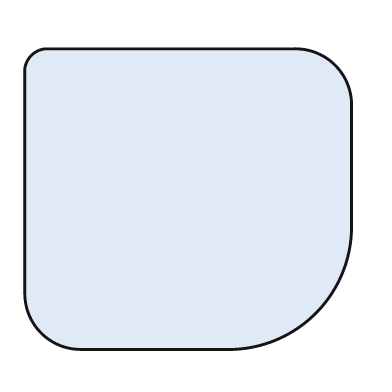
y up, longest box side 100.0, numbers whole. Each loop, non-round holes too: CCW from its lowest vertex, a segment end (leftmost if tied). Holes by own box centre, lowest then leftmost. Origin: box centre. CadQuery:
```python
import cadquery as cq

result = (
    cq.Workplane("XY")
    .moveTo(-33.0, -46.0)
    .lineTo(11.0, -46.0)
    .threePointArc((39.0, -35.0), (50.0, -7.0))
    .lineTo(50.0, 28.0)
    .threePointArc((45.0, 41.0), (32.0, 46.0))
    .lineTo(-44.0, 46.0)
    .threePointArc((-48.0, 44.0), (-50.0, 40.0))
    .lineTo(-50.0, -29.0)
    .threePointArc((-45.0, -41.0), (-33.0, -46.0))
    .close()
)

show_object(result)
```